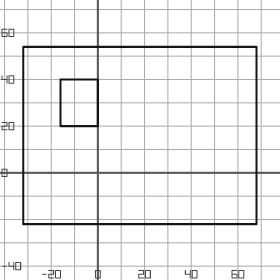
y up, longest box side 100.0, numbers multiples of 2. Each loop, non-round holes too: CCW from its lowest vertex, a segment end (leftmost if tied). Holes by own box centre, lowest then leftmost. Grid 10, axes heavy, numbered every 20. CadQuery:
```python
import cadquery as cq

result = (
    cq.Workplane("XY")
    .moveTo(-32.0, -22.0)
    .lineTo(68.0, -22.0)
    .lineTo(68.0, 54.0)
    .lineTo(-32.0, 54.0)
    .close()
    .moveTo(-16.0, 20.0)
    .lineTo(0.0, 20.0)
    .lineTo(0.0, 40.0)
    .lineTo(-16.0, 40.0)
    .close()
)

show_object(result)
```